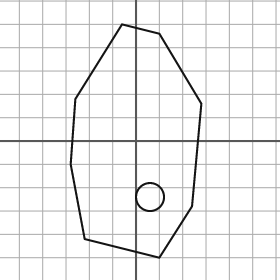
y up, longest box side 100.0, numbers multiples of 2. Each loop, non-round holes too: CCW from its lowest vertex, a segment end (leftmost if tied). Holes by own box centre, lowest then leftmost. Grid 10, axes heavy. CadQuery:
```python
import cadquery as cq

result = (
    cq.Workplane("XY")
    .moveTo(10.0, -50.0)
    .lineTo(24.0, -28.0)
    .lineTo(28.0, 16.0)
    .lineTo(10.0, 46.0)
    .lineTo(-6.0, 50.0)
    .lineTo(-26.0, 18.0)
    .lineTo(-28.0, -10.0)
    .lineTo(-22.0, -42.0)
    .close()
    .moveTo(6.0, -24.0)
    .circle(6.0)
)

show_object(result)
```